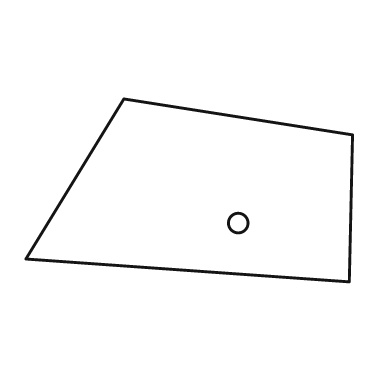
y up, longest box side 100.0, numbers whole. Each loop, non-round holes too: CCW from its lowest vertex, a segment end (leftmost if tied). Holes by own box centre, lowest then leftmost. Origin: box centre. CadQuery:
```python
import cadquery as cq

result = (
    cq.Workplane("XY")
    .moveTo(49.0, -28.0)
    .lineTo(50.0, 17.0)
    .lineTo(-20.0, 28.0)
    .lineTo(-50.0, -21.0)
    .close()
    .moveTo(15.0, -10.0)
    .circle(3.0)
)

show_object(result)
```